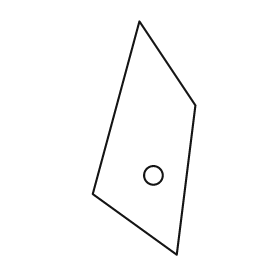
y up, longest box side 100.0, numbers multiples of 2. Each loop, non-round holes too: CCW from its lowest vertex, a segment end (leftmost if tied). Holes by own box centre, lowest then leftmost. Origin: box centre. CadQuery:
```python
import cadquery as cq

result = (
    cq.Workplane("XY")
    .moveTo(14.0, -50.0)
    .lineTo(22.0, 14.0)
    .lineTo(-2.0, 50.0)
    .lineTo(-22.0, -24.0)
    .close()
    .moveTo(4.0, -16.0)
    .circle(4.0)
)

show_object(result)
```